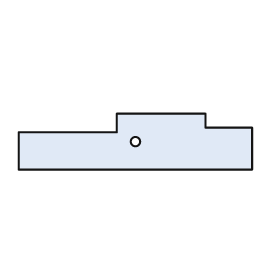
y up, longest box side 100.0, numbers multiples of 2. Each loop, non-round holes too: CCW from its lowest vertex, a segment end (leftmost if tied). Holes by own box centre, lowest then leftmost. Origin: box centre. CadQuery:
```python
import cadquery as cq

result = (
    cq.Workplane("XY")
    .moveTo(-50.0, -12.0)
    .lineTo(50.0, -12.0)
    .lineTo(50.0, 6.0)
    .lineTo(30.0, 6.0)
    .lineTo(30.0, 12.0)
    .lineTo(-8.0, 12.0)
    .lineTo(-8.0, 4.0)
    .lineTo(-50.0, 4.0)
    .close()
    .moveTo(0.0, 0.0)
    .circle(2.0)
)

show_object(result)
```